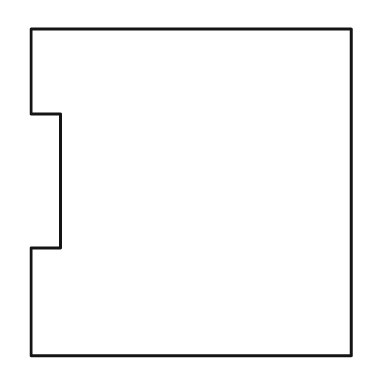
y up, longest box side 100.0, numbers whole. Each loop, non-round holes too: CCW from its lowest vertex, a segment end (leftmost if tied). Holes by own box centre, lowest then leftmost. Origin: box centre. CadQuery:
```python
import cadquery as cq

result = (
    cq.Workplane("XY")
    .moveTo(-49.0, -50.0)
    .lineTo(49.0, -50.0)
    .lineTo(49.0, 50.0)
    .lineTo(-49.0, 50.0)
    .lineTo(-49.0, 24.0)
    .lineTo(-40.0, 24.0)
    .lineTo(-40.0, -17.0)
    .lineTo(-49.0, -17.0)
    .close()
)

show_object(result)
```